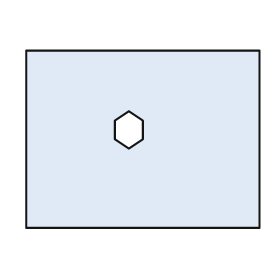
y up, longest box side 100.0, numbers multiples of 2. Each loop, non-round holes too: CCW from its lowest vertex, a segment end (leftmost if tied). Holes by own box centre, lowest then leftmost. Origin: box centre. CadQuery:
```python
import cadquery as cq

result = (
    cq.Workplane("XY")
    .moveTo(-50.0, -38.0)
    .lineTo(50.0, -38.0)
    .lineTo(50.0, 38.0)
    .lineTo(-50.0, 38.0)
    .close()
    .moveTo(-6.0, -4.0)
    .lineTo(0.0, 0.0)
    .lineTo(0.0, 8.0)
    .lineTo(-6.0, 12.0)
    .lineTo(-12.0, 8.0)
    .lineTo(-12.0, 0.0)
    .close()
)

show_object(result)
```